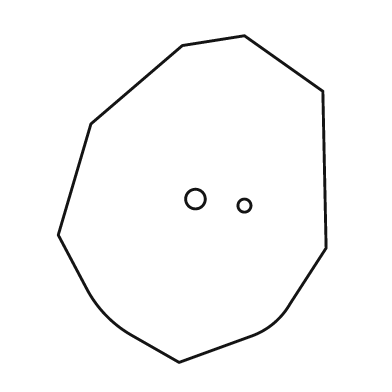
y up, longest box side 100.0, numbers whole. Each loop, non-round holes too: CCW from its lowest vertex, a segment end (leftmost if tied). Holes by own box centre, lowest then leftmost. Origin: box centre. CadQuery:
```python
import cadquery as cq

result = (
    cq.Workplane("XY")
    .moveTo(-4.0, -50.0)
    .lineTo(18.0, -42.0)
    .threePointArc((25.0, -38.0), (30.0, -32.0))
    .lineTo(41.0, -15.0)
    .lineTo(40.0, 33.0)
    .lineTo(16.0, 50.0)
    .lineTo(-3.0, 47.0)
    .lineTo(-31.0, 23.0)
    .lineTo(-41.0, -11.0)
    .lineTo(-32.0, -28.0)
    .threePointArc((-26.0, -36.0), (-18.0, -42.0))
    .close()
    .moveTo(16.0, -2.0)
    .circle(2.0)
    .moveTo(1.0, 0.0)
    .circle(3.0)
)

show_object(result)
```